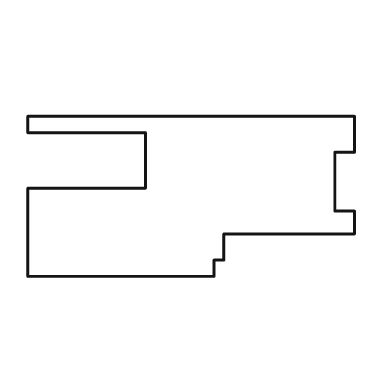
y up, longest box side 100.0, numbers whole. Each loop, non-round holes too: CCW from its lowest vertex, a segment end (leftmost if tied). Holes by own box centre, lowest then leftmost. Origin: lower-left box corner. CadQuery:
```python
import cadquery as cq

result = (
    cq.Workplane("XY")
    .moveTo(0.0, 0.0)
    .lineTo(57.0, 0.0)
    .lineTo(57.0, 5.0)
    .lineTo(60.0, 5.0)
    .lineTo(60.0, 13.0)
    .lineTo(100.0, 13.0)
    .lineTo(100.0, 20.0)
    .lineTo(94.0, 20.0)
    .lineTo(94.0, 38.0)
    .lineTo(100.0, 38.0)
    .lineTo(100.0, 49.0)
    .lineTo(0.0, 49.0)
    .lineTo(0.0, 44.0)
    .lineTo(36.0, 44.0)
    .lineTo(36.0, 27.0)
    .lineTo(0.0, 27.0)
    .close()
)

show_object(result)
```